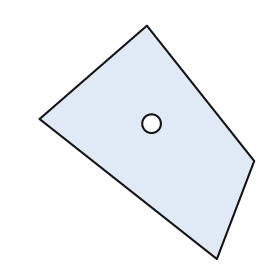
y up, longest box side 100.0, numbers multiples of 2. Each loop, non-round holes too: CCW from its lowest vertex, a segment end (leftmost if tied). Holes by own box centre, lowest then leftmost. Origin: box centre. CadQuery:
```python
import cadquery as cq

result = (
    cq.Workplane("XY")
    .moveTo(30.0, -50.0)
    .lineTo(46.0, -8.0)
    .lineTo(0.0, 50.0)
    .lineTo(-46.0, 10.0)
    .close()
    .moveTo(2.0, 8.0)
    .circle(4.0)
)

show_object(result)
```